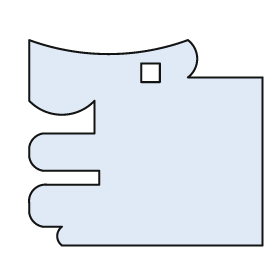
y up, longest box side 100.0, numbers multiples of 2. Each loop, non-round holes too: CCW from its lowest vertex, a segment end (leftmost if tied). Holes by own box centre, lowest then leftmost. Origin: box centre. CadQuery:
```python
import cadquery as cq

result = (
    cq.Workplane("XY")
    .moveTo(-36.0, -44.0)
    .lineTo(50.0, -44.0)
    .lineTo(50.0, 28.0)
    .lineTo(18.0, 28.0)
    .threePointArc((22.0, 36.0), (18.0, 44.0))
    .threePointArc((-16.0, 38.0), (-50.0, 44.0))
    .lineTo(-50.0, 18.0)
    .threePointArc((-36.0, 12.0), (-22.0, 18.0))
    .lineTo(-22.0, 4.0)
    .lineTo(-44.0, 4.0)
    .threePointArc((-48.0, 2.0), (-50.0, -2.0))
    .lineTo(-50.0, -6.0)
    .threePointArc((-48.0, -10.0), (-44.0, -12.0))
    .lineTo(-20.0, -12.0)
    .lineTo(-20.0, -18.0)
    .lineTo(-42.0, -18.0)
    .threePointArc((-48.0, -20.0), (-50.0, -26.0))
    .lineTo(-50.0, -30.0)
    .threePointArc((-48.0, -34.0), (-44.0, -36.0))
    .lineTo(-36.0, -36.0)
    .threePointArc((-38.0, -40.0), (-36.0, -44.0))
    .close()
    .moveTo(-2.0, 26.0)
    .lineTo(6.0, 26.0)
    .lineTo(6.0, 34.0)
    .lineTo(-2.0, 34.0)
    .close()
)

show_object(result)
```